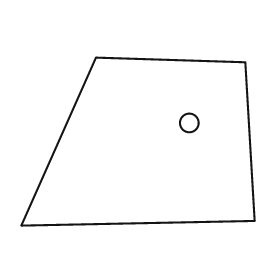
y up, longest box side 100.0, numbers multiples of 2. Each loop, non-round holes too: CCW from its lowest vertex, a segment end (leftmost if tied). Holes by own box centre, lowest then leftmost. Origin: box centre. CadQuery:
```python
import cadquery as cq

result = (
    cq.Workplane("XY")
    .moveTo(-50.0, -36.0)
    .lineTo(50.0, -34.0)
    .lineTo(46.0, 34.0)
    .lineTo(-18.0, 36.0)
    .close()
    .moveTo(22.0, 8.0)
    .circle(4.0)
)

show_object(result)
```